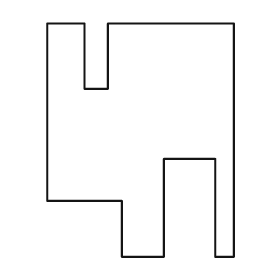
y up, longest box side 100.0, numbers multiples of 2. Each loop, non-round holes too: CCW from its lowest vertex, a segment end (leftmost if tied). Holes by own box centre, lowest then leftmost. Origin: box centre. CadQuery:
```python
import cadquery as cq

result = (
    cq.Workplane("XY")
    .moveTo(-8.0, -50.0)
    .lineTo(10.0, -50.0)
    .lineTo(10.0, -8.0)
    .lineTo(32.0, -8.0)
    .lineTo(32.0, -50.0)
    .lineTo(40.0, -50.0)
    .lineTo(40.0, 50.0)
    .lineTo(-14.0, 50.0)
    .lineTo(-14.0, 22.0)
    .lineTo(-24.0, 22.0)
    .lineTo(-24.0, 50.0)
    .lineTo(-40.0, 50.0)
    .lineTo(-40.0, -26.0)
    .lineTo(-8.0, -26.0)
    .close()
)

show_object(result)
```